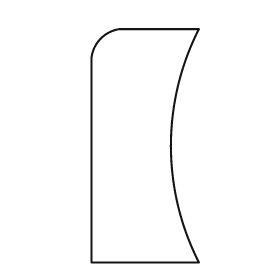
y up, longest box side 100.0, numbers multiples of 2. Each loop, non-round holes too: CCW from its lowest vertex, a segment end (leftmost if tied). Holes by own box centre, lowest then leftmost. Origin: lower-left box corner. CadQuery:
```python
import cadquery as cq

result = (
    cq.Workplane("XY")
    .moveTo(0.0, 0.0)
    .lineTo(46.0, 0.0)
    .threePointArc((34.0, 50.0), (46.0, 100.0))
    .lineTo(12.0, 100.0)
    .threePointArc((4.0, 96.0), (0.0, 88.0))
    .close()
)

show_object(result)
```